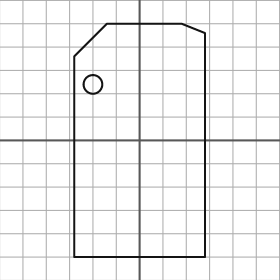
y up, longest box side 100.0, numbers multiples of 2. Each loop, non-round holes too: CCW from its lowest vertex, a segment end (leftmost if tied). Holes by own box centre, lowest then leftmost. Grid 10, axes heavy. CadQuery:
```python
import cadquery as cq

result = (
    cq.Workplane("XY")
    .moveTo(-28.0, -50.0)
    .lineTo(28.0, -50.0)
    .lineTo(28.0, 46.0)
    .lineTo(18.0, 50.0)
    .lineTo(-14.0, 50.0)
    .lineTo(-28.0, 36.0)
    .close()
    .moveTo(-20.0, 24.0)
    .circle(4.0)
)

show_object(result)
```